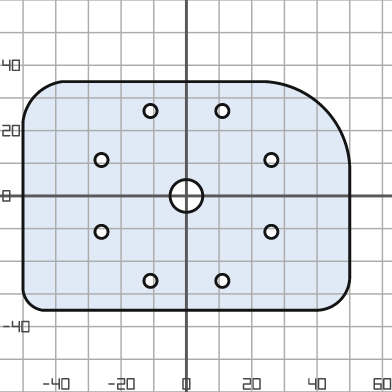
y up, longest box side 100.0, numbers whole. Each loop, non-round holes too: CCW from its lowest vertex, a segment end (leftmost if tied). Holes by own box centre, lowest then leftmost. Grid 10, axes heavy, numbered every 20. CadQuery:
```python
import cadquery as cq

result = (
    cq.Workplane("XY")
    .moveTo(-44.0, -35.0)
    .lineTo(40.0, -35.0)
    .threePointArc((47.0, -32.0), (50.0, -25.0))
    .lineTo(50.0, 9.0)
    .threePointArc((42.0, 27.0), (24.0, 35.0))
    .lineTo(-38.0, 35.0)
    .threePointArc((-46.0, 31.0), (-50.0, 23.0))
    .lineTo(-50.0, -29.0)
    .threePointArc((-48.0, -33.0), (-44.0, -35.0))
    .close()
    .moveTo(-11.0, -26.0)
    .circle(2.0)
    .moveTo(11.0, -26.0)
    .circle(2.0)
    .moveTo(-26.0, -11.0)
    .circle(2.0)
    .moveTo(26.0, -11.0)
    .circle(2.0)
    .moveTo(0.0, 0.0)
    .circle(5.0)
    .moveTo(-26.0, 11.0)
    .circle(2.0)
    .moveTo(26.0, 11.0)
    .circle(2.0)
    .moveTo(-11.0, 26.0)
    .circle(2.0)
    .moveTo(11.0, 26.0)
    .circle(2.0)
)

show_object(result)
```